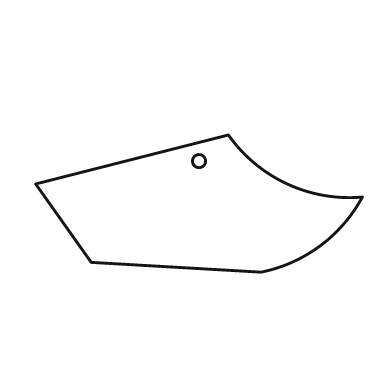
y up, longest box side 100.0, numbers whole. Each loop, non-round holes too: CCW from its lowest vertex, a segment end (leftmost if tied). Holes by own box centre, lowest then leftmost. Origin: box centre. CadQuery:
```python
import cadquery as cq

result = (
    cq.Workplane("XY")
    .moveTo(19.0, -21.0)
    .threePointArc((37.0, -13.0), (50.0, 2.0))
    .threePointArc((27.0, 6.0), (9.0, 21.0))
    .lineTo(-50.0, 6.0)
    .lineTo(-33.0, -18.0)
    .close()
    .moveTo(0.0, 13.0)
    .circle(2.0)
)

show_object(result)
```